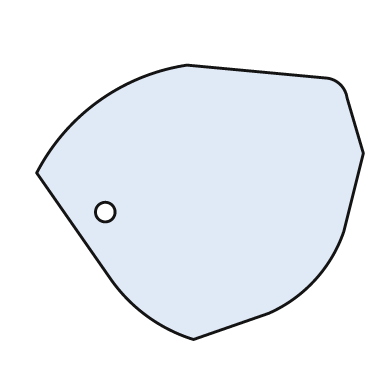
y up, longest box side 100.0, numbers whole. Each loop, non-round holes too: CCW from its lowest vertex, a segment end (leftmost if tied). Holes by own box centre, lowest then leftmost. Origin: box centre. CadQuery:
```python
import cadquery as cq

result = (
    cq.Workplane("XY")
    .moveTo(-2.0, -42.0)
    .lineTo(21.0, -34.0)
    .threePointArc((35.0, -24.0), (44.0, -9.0))
    .lineTo(50.0, 15.0)
    .lineTo(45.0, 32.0)
    .threePointArc((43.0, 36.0), (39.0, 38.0))
    .lineTo(-4.0, 42.0)
    .threePointArc((-31.0, 31.0), (-50.0, 9.0))
    .lineTo(-27.0, -24.0)
    .threePointArc((-16.0, -35.0), (-2.0, -42.0))
    .close()
    .moveTo(-29.0, -3.0)
    .circle(3.0)
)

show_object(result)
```